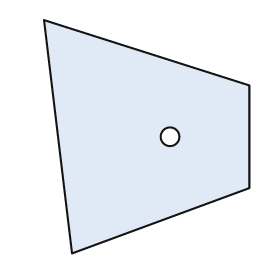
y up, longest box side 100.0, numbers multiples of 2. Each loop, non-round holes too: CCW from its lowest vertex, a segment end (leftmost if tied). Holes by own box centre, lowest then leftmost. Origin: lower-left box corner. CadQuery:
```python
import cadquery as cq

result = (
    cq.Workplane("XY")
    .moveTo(12.0, 0.0)
    .lineTo(88.0, 28.0)
    .lineTo(88.0, 72.0)
    .lineTo(0.0, 100.0)
    .close()
    .moveTo(54.0, 50.0)
    .circle(4.0)
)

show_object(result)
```